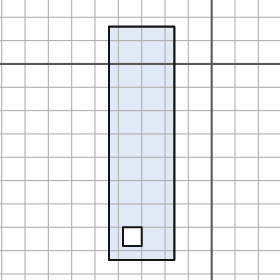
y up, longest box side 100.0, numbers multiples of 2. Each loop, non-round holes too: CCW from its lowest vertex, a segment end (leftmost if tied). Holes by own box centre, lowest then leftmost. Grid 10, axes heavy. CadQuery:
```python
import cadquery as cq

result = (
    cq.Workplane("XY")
    .moveTo(-44.0, -84.0)
    .lineTo(-16.0, -84.0)
    .lineTo(-16.0, 16.0)
    .lineTo(-44.0, 16.0)
    .close()
    .moveTo(-38.0, -78.0)
    .lineTo(-30.0, -78.0)
    .lineTo(-30.0, -70.0)
    .lineTo(-38.0, -70.0)
    .close()
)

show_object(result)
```